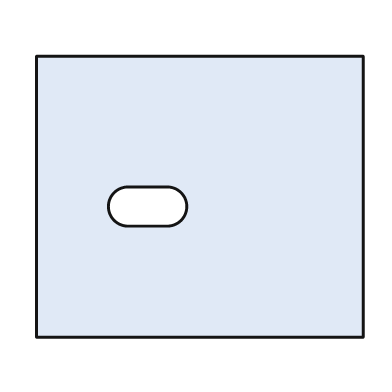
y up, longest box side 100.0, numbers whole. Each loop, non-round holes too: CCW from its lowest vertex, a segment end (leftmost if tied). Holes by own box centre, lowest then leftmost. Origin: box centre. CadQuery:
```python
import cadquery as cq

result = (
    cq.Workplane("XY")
    .moveTo(-50.0, -43.0)
    .lineTo(50.0, -43.0)
    .lineTo(50.0, 43.0)
    .lineTo(-50.0, 43.0)
    .close()
    .moveTo(-22.0, -9.0)
    .lineTo(-10.0, -9.0)
    .threePointArc((-4.0, -3.0), (-10.0, 3.0))
    .lineTo(-22.0, 3.0)
    .threePointArc((-28.0, -3.0), (-22.0, -9.0))
    .close()
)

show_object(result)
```